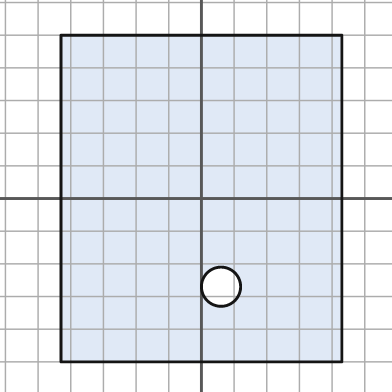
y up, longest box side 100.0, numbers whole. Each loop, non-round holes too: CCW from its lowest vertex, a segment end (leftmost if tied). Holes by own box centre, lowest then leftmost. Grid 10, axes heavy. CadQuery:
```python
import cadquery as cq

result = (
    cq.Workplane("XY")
    .moveTo(-43.0, -50.0)
    .lineTo(43.0, -50.0)
    .lineTo(43.0, 50.0)
    .lineTo(-43.0, 50.0)
    .close()
    .moveTo(6.0, -27.0)
    .circle(6.0)
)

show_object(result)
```